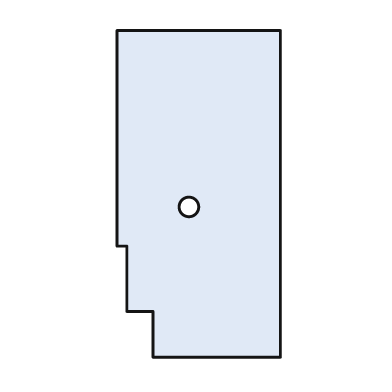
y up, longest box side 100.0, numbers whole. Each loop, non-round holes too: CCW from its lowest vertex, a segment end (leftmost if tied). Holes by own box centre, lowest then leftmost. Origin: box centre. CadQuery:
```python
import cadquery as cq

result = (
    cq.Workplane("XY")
    .moveTo(-14.0, -50.0)
    .lineTo(25.0, -50.0)
    .lineTo(25.0, 50.0)
    .lineTo(-25.0, 50.0)
    .lineTo(-25.0, -16.0)
    .lineTo(-22.0, -16.0)
    .lineTo(-22.0, -36.0)
    .lineTo(-14.0, -36.0)
    .close()
    .moveTo(-3.0, -4.0)
    .circle(3.0)
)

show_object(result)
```